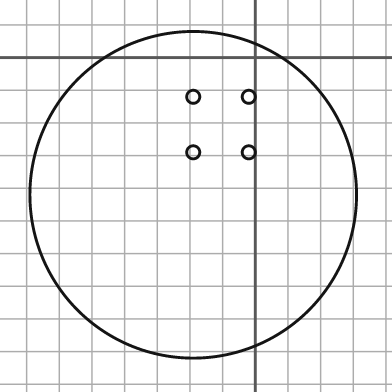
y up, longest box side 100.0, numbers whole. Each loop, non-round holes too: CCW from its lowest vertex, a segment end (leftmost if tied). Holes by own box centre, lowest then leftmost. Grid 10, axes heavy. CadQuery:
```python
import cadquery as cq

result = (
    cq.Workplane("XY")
    .moveTo(-19.0, -42.0)
    .circle(50.0)
    .moveTo(-19.0, -29.0)
    .circle(2.0)
    .moveTo(-2.0, -29.0)
    .circle(2.0)
    .moveTo(-19.0, -12.0)
    .circle(2.0)
    .moveTo(-2.0, -12.0)
    .circle(2.0)
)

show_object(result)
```